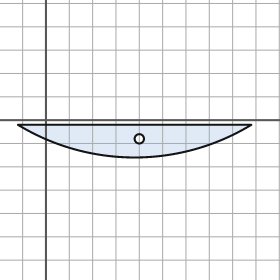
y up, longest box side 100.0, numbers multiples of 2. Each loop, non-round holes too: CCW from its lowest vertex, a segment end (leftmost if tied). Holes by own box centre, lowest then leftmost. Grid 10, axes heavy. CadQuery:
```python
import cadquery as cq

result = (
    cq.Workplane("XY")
    .moveTo(-12.0, -2.0)
    .threePointArc((38.0, -16.0), (88.0, -2.0))
    .close()
    .moveTo(40.0, -8.0)
    .circle(2.0)
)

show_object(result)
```